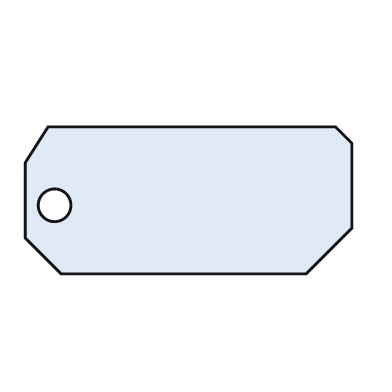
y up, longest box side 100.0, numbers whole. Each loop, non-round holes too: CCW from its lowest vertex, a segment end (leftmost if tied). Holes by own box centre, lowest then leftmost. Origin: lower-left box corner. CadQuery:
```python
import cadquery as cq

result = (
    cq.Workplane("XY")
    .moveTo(11.0, 0.0)
    .lineTo(86.0, 0.0)
    .lineTo(100.0, 14.0)
    .lineTo(100.0, 40.0)
    .lineTo(95.0, 45.0)
    .lineTo(7.0, 45.0)
    .lineTo(0.0, 34.0)
    .lineTo(0.0, 11.0)
    .close()
    .moveTo(9.0, 21.0)
    .circle(5.0)
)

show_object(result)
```